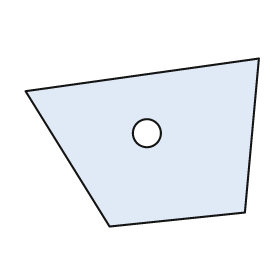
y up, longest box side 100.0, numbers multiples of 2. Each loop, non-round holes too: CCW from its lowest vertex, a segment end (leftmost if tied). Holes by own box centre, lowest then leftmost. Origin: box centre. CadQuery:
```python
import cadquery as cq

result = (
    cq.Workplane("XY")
    .moveTo(-14.0, -36.0)
    .lineTo(44.0, -30.0)
    .lineTo(50.0, 36.0)
    .lineTo(-50.0, 22.0)
    .close()
    .moveTo(2.0, 4.0)
    .circle(6.0)
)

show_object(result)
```